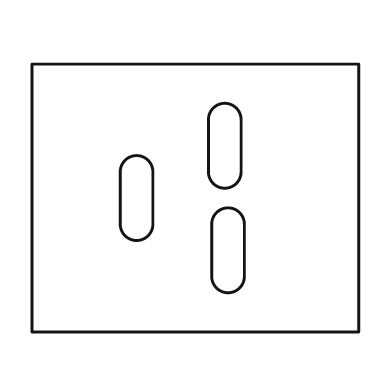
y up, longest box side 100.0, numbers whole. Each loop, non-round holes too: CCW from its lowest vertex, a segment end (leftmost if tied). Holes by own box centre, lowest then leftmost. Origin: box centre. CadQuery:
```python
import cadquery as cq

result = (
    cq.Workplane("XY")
    .moveTo(-50.0, -41.0)
    .lineTo(50.0, -41.0)
    .lineTo(50.0, 41.0)
    .lineTo(-50.0, 41.0)
    .close()
    .moveTo(5.0, -24.0)
    .threePointArc((10.0, -29.0), (15.0, -24.0))
    .lineTo(15.0, -8.0)
    .threePointArc((10.0, -3.0), (5.0, -8.0))
    .close()
    .moveTo(-23.0, -8.0)
    .threePointArc((-18.0, -13.0), (-13.0, -8.0))
    .lineTo(-13.0, 8.0)
    .threePointArc((-18.0, 13.0), (-23.0, 8.0))
    .close()
    .moveTo(4.0, 8.0)
    .threePointArc((9.0, 3.0), (14.0, 8.0))
    .lineTo(14.0, 24.0)
    .threePointArc((9.0, 29.0), (4.0, 24.0))
    .close()
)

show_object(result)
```